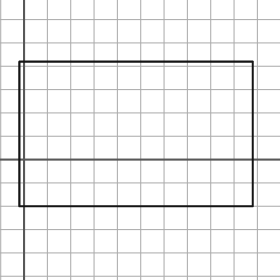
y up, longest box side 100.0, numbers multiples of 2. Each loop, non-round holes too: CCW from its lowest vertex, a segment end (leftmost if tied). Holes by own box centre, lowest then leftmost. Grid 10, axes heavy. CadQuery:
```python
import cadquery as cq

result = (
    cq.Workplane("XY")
    .moveTo(-2.0, -20.0)
    .lineTo(98.0, -20.0)
    .lineTo(98.0, 42.0)
    .lineTo(-2.0, 42.0)
    .close()
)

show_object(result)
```